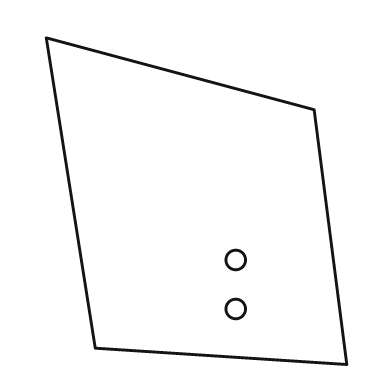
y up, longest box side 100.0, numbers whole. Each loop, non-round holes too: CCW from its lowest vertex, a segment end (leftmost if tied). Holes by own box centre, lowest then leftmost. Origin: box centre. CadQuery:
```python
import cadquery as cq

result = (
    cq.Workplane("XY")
    .moveTo(46.0, -50.0)
    .lineTo(36.0, 28.0)
    .lineTo(-46.0, 50.0)
    .lineTo(-31.0, -45.0)
    .close()
    .moveTo(12.0, -33.0)
    .circle(3.0)
    .moveTo(12.0, -18.0)
    .circle(3.0)
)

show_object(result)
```